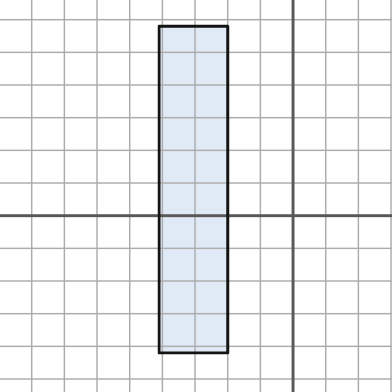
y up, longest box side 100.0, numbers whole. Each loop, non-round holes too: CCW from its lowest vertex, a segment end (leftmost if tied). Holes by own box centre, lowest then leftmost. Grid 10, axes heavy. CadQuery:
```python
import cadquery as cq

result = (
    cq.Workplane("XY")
    .moveTo(-41.0, -42.0)
    .lineTo(-20.0, -42.0)
    .lineTo(-20.0, 58.0)
    .lineTo(-41.0, 58.0)
    .close()
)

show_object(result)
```